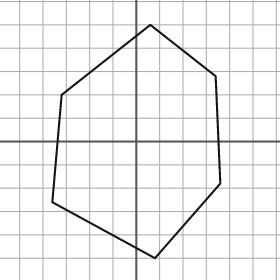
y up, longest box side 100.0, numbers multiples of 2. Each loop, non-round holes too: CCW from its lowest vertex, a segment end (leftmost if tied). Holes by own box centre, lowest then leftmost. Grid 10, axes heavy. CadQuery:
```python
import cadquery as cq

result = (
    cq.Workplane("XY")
    .moveTo(8.0, -50.0)
    .lineTo(36.0, -18.0)
    .lineTo(34.0, 28.0)
    .lineTo(6.0, 50.0)
    .lineTo(-32.0, 20.0)
    .lineTo(-36.0, -26.0)
    .close()
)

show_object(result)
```